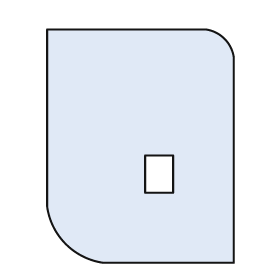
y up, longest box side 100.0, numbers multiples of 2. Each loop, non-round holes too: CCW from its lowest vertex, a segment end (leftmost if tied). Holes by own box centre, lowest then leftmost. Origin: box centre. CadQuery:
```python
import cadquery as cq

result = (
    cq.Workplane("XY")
    .moveTo(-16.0, -50.0)
    .lineTo(40.0, -50.0)
    .lineTo(40.0, 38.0)
    .threePointArc((36.0, 46.0), (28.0, 50.0))
    .lineTo(-40.0, 50.0)
    .lineTo(-40.0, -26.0)
    .threePointArc((-32.0, -42.0), (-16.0, -50.0))
    .close()
    .moveTo(2.0, -20.0)
    .lineTo(14.0, -20.0)
    .lineTo(14.0, -4.0)
    .lineTo(2.0, -4.0)
    .close()
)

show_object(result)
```